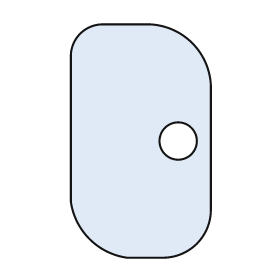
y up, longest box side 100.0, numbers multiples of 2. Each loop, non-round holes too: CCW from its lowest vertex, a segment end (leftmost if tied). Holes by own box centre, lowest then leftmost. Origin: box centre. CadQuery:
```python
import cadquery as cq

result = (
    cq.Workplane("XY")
    .moveTo(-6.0, -50.0)
    .lineTo(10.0, -50.0)
    .threePointArc((24.0, -44.0), (30.0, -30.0))
    .lineTo(30.0, 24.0)
    .threePointArc((22.0, 42.0), (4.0, 50.0))
    .lineTo(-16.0, 50.0)
    .threePointArc((-26.0, 46.0), (-30.0, 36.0))
    .lineTo(-30.0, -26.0)
    .threePointArc((-22.0, -42.0), (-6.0, -50.0))
    .close()
    .moveTo(16.0, 0.0)
    .circle(8.0)
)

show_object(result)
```